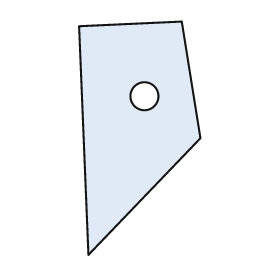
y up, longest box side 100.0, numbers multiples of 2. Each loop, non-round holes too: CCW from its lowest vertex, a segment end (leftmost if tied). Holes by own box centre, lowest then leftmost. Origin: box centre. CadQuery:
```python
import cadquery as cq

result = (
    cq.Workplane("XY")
    .moveTo(-22.0, -50.0)
    .lineTo(26.0, 0.0)
    .lineTo(18.0, 50.0)
    .lineTo(-26.0, 48.0)
    .close()
    .moveTo(2.0, 18.0)
    .circle(6.0)
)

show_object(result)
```